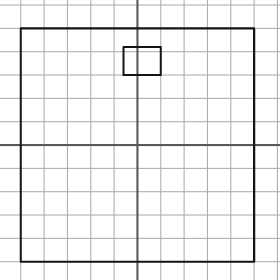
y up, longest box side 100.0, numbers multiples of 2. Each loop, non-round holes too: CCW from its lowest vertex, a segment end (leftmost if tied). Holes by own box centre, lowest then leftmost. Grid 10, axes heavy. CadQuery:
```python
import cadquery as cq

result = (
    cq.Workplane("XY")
    .moveTo(-50.0, -50.0)
    .lineTo(50.0, -50.0)
    .lineTo(50.0, 50.0)
    .lineTo(-50.0, 50.0)
    .close()
    .moveTo(-6.0, 30.0)
    .lineTo(10.0, 30.0)
    .lineTo(10.0, 42.0)
    .lineTo(-6.0, 42.0)
    .close()
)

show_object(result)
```